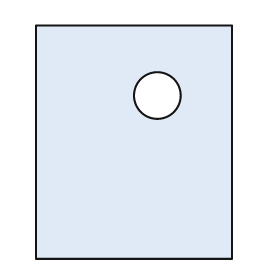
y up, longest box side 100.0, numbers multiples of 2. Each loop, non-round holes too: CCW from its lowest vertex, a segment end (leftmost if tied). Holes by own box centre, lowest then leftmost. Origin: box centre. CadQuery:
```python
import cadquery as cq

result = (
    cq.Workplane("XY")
    .moveTo(-42.0, -50.0)
    .lineTo(42.0, -50.0)
    .lineTo(42.0, 50.0)
    .lineTo(-42.0, 50.0)
    .close()
    .moveTo(10.0, 20.0)
    .circle(10.0)
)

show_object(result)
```